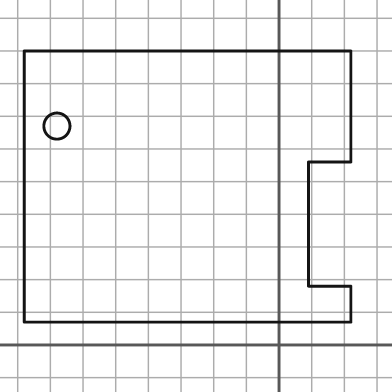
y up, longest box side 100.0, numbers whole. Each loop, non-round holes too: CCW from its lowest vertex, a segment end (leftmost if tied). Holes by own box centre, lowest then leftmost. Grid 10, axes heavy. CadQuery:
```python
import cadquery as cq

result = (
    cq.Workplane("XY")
    .moveTo(-78.0, 7.0)
    .lineTo(22.0, 7.0)
    .lineTo(22.0, 18.0)
    .lineTo(9.0, 18.0)
    .lineTo(9.0, 56.0)
    .lineTo(22.0, 56.0)
    .lineTo(22.0, 90.0)
    .lineTo(-78.0, 90.0)
    .close()
    .moveTo(-68.0, 67.0)
    .circle(4.0)
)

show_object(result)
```